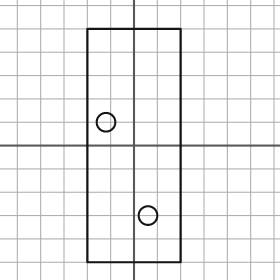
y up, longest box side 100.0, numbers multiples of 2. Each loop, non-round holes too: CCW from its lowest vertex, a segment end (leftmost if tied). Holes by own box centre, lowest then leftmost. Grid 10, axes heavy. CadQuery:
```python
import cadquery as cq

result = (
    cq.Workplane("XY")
    .moveTo(-20.0, -50.0)
    .lineTo(20.0, -50.0)
    .lineTo(20.0, 50.0)
    .lineTo(-20.0, 50.0)
    .close()
    .moveTo(6.0, -30.0)
    .circle(4.0)
    .moveTo(-12.0, 10.0)
    .circle(4.0)
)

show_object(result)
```